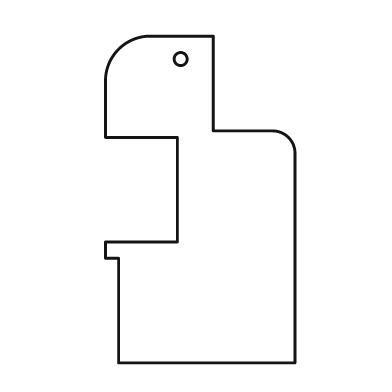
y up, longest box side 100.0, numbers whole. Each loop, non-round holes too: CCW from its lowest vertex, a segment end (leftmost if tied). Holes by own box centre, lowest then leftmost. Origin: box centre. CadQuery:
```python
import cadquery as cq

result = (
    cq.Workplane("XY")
    .moveTo(-25.0, -50.0)
    .lineTo(29.0, -50.0)
    .lineTo(29.0, 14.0)
    .threePointArc((27.0, 19.0), (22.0, 21.0))
    .lineTo(4.0, 21.0)
    .lineTo(4.0, 50.0)
    .lineTo(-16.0, 50.0)
    .threePointArc((-25.0, 46.0), (-29.0, 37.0))
    .lineTo(-29.0, 19.0)
    .lineTo(-7.0, 19.0)
    .lineTo(-7.0, -13.0)
    .lineTo(-29.0, -13.0)
    .lineTo(-29.0, -18.0)
    .lineTo(-25.0, -18.0)
    .close()
    .moveTo(-6.0, 43.0)
    .circle(2.0)
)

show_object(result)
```